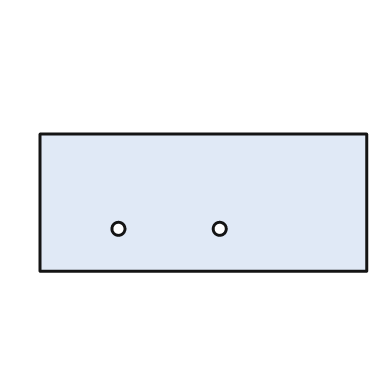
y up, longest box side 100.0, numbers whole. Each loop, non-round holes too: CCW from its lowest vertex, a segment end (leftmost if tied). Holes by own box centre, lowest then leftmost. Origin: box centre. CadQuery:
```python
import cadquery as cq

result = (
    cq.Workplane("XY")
    .moveTo(-50.0, -21.0)
    .lineTo(50.0, -21.0)
    .lineTo(50.0, 21.0)
    .lineTo(-50.0, 21.0)
    .close()
    .moveTo(-26.0, -8.0)
    .circle(2.0)
    .moveTo(5.0, -8.0)
    .circle(2.0)
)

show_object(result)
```